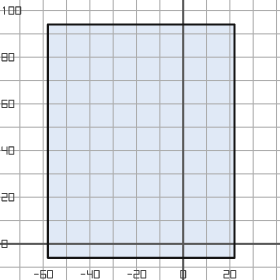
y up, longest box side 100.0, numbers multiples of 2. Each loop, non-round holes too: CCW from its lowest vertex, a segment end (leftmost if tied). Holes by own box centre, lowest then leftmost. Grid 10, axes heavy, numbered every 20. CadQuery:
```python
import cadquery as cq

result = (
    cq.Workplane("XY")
    .moveTo(-58.0, -6.0)
    .lineTo(22.0, -6.0)
    .lineTo(22.0, 94.0)
    .lineTo(-58.0, 94.0)
    .close()
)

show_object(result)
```